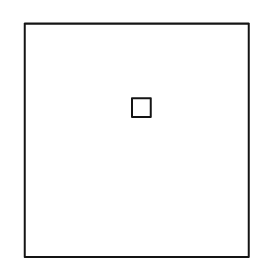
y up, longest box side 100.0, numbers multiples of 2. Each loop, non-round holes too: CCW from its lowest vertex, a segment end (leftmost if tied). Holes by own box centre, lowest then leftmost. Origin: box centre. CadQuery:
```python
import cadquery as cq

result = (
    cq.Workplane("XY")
    .moveTo(-48.0, -50.0)
    .lineTo(48.0, -50.0)
    .lineTo(48.0, 50.0)
    .lineTo(-48.0, 50.0)
    .close()
    .moveTo(-2.0, 10.0)
    .lineTo(6.0, 10.0)
    .lineTo(6.0, 18.0)
    .lineTo(-2.0, 18.0)
    .close()
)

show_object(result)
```